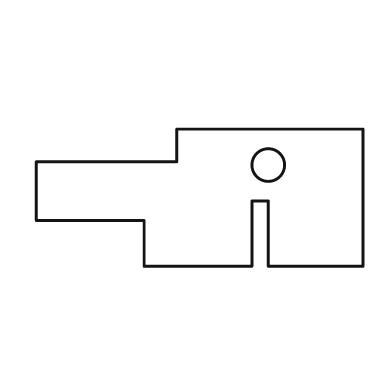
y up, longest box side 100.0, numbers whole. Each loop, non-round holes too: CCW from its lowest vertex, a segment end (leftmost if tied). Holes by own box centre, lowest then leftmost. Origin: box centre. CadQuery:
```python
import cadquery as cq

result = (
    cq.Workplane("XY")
    .moveTo(-17.0, -21.0)
    .lineTo(16.0, -21.0)
    .lineTo(16.0, -1.0)
    .lineTo(21.0, -1.0)
    .lineTo(21.0, -21.0)
    .lineTo(50.0, -21.0)
    .lineTo(50.0, 21.0)
    .lineTo(-7.0, 21.0)
    .lineTo(-7.0, 11.0)
    .lineTo(-50.0, 11.0)
    .lineTo(-50.0, -7.0)
    .lineTo(-17.0, -7.0)
    .close()
    .moveTo(21.0, 10.0)
    .circle(5.0)
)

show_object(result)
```